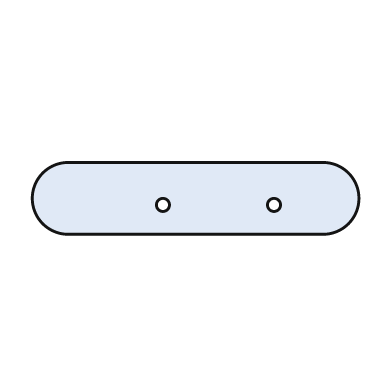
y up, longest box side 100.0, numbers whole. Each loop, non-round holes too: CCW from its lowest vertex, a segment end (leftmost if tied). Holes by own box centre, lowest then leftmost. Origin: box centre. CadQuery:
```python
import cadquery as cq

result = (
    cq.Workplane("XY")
    .moveTo(-39.0, -11.0)
    .lineTo(39.0, -11.0)
    .threePointArc((50.0, 0.0), (39.0, 11.0))
    .lineTo(-39.0, 11.0)
    .threePointArc((-50.0, 0.0), (-39.0, -11.0))
    .close()
    .moveTo(-10.0, -2.0)
    .circle(2.0)
    .moveTo(24.0, -2.0)
    .circle(2.0)
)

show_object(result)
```